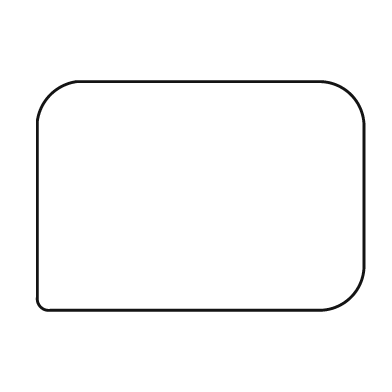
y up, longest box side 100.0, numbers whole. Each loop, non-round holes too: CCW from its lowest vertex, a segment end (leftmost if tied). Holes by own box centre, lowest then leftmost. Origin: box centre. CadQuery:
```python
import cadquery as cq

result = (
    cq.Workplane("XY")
    .moveTo(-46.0, -35.0)
    .lineTo(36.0, -35.0)
    .threePointArc((46.0, -31.0), (50.0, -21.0))
    .lineTo(50.0, 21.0)
    .threePointArc((46.0, 31.0), (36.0, 35.0))
    .lineTo(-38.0, 35.0)
    .threePointArc((-46.0, 31.0), (-50.0, 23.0))
    .lineTo(-50.0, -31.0)
    .threePointArc((-49.0, -34.0), (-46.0, -35.0))
    .close()
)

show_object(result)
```